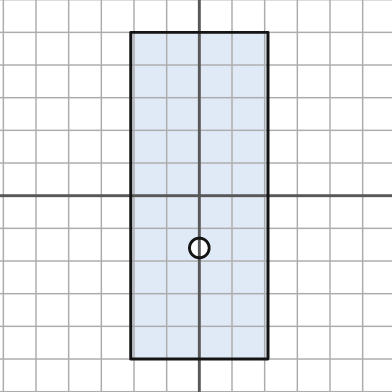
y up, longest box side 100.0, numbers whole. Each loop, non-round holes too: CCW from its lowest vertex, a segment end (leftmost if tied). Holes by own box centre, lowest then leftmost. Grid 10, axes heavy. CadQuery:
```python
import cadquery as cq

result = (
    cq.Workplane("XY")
    .moveTo(-21.0, -50.0)
    .lineTo(21.0, -50.0)
    .lineTo(21.0, 50.0)
    .lineTo(-21.0, 50.0)
    .close()
    .moveTo(0.0, -16.0)
    .circle(3.0)
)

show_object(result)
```